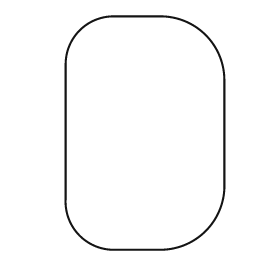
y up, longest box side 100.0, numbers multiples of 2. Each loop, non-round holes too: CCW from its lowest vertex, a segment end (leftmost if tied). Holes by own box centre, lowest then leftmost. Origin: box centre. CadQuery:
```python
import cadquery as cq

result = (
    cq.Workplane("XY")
    .moveTo(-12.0, -50.0)
    .lineTo(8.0, -50.0)
    .threePointArc((26.0, -42.0), (34.0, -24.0))
    .lineTo(34.0, 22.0)
    .threePointArc((26.0, 42.0), (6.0, 50.0))
    .lineTo(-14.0, 50.0)
    .threePointArc((-28.0, 44.0), (-34.0, 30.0))
    .lineTo(-34.0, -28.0)
    .threePointArc((-28.0, -44.0), (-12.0, -50.0))
    .close()
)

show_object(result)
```